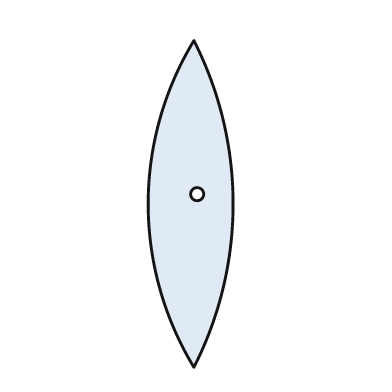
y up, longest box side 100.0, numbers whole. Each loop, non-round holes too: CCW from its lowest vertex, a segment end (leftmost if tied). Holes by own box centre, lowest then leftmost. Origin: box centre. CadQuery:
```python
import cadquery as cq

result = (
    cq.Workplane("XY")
    .moveTo(1.0, -50.0)
    .threePointArc((13.0, 0.0), (1.0, 50.0))
    .threePointArc((-13.0, 0.0), (1.0, -50.0))
    .close()
    .moveTo(2.0, 3.0)
    .circle(2.0)
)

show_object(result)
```